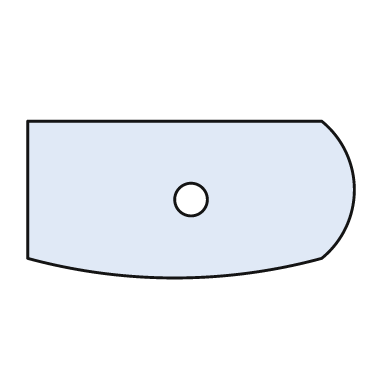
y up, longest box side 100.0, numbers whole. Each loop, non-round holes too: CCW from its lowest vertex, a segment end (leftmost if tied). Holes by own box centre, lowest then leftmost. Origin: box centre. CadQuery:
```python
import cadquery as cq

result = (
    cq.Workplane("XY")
    .moveTo(-50.0, -18.0)
    .threePointArc((-5.0, -24.0), (40.0, -18.0))
    .threePointArc((50.0, 3.0), (40.0, 24.0))
    .lineTo(-50.0, 24.0)
    .close()
    .moveTo(0.0, 0.0)
    .circle(5.0)
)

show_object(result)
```